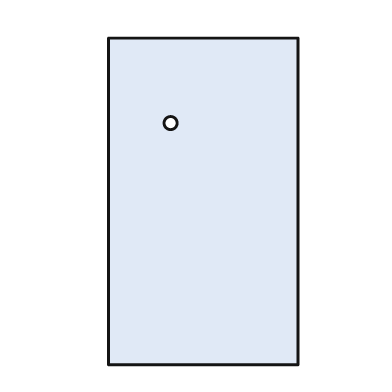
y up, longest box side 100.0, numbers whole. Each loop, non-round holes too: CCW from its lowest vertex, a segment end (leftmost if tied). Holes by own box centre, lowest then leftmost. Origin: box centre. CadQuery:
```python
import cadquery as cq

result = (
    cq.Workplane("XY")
    .moveTo(-29.0, -50.0)
    .lineTo(29.0, -50.0)
    .lineTo(29.0, 50.0)
    .lineTo(-29.0, 50.0)
    .close()
    .moveTo(-10.0, 24.0)
    .circle(2.0)
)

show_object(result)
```